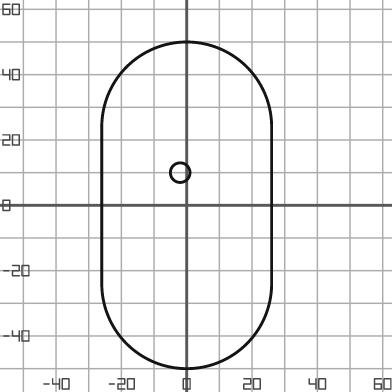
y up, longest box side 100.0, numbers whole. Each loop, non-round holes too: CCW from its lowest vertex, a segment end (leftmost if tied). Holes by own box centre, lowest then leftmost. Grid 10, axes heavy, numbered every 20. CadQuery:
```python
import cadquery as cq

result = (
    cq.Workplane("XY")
    .moveTo(-26.0, -24.0)
    .threePointArc((0.0, -50.0), (26.0, -24.0))
    .lineTo(26.0, 24.0)
    .threePointArc((0.0, 50.0), (-26.0, 24.0))
    .close()
    .moveTo(-2.0, 10.0)
    .circle(3.0)
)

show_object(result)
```